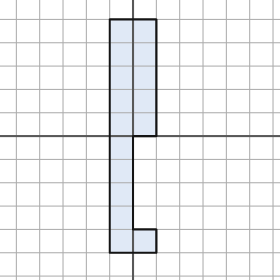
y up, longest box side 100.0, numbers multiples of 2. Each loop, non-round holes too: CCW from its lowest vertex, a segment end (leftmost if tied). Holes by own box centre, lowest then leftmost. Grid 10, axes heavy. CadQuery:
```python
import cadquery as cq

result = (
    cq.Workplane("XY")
    .moveTo(-10.0, -50.0)
    .lineTo(10.0, -50.0)
    .lineTo(10.0, -40.0)
    .lineTo(0.0, -40.0)
    .lineTo(0.0, 0.0)
    .lineTo(10.0, 0.0)
    .lineTo(10.0, 50.0)
    .lineTo(-10.0, 50.0)
    .close()
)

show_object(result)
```